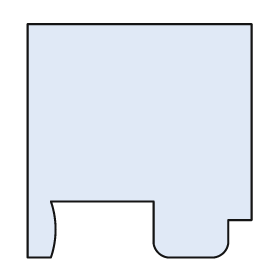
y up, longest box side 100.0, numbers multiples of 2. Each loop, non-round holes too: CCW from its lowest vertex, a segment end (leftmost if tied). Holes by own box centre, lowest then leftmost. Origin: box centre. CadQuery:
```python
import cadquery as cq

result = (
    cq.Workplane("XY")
    .moveTo(-48.0, -50.0)
    .lineTo(-38.0, -50.0)
    .threePointArc((-36.0, -38.0), (-38.0, -26.0))
    .lineTo(6.0, -26.0)
    .lineTo(6.0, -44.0)
    .threePointArc((8.0, -48.0), (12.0, -50.0))
    .lineTo(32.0, -50.0)
    .threePointArc((36.0, -48.0), (38.0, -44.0))
    .lineTo(38.0, -34.0)
    .lineTo(48.0, -34.0)
    .lineTo(48.0, 50.0)
    .lineTo(-48.0, 50.0)
    .close()
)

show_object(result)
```